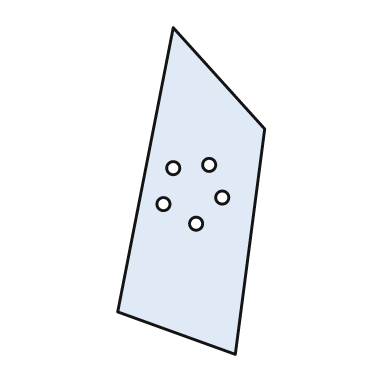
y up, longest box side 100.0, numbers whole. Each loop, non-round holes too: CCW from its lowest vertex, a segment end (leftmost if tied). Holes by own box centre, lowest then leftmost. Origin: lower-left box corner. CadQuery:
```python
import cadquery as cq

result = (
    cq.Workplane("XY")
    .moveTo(36.0, 0.0)
    .lineTo(45.0, 69.0)
    .lineTo(17.0, 100.0)
    .lineTo(0.0, 13.0)
    .close()
    .moveTo(24.0, 40.0)
    .circle(2.0)
    .moveTo(14.0, 46.0)
    .circle(2.0)
    .moveTo(32.0, 48.0)
    .circle(2.0)
    .moveTo(17.0, 57.0)
    .circle(2.0)
    .moveTo(28.0, 58.0)
    .circle(2.0)
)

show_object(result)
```